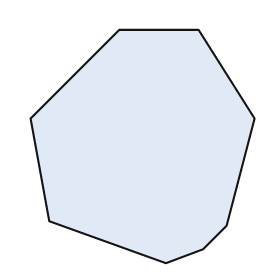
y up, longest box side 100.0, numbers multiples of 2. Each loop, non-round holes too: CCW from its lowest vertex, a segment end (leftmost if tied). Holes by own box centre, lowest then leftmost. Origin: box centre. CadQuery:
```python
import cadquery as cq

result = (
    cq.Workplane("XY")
    .moveTo(10.0, -50.0)
    .lineTo(26.0, -44.0)
    .lineTo(36.0, -34.0)
    .lineTo(48.0, 12.0)
    .lineTo(24.0, 50.0)
    .lineTo(-10.0, 50.0)
    .lineTo(-48.0, 12.0)
    .lineTo(-40.0, -32.0)
    .close()
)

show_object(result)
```